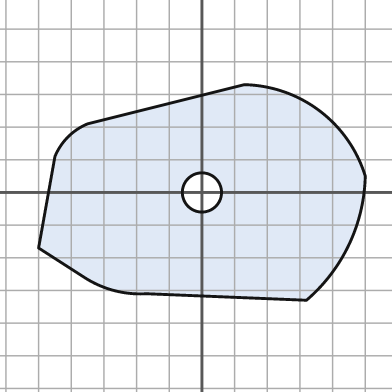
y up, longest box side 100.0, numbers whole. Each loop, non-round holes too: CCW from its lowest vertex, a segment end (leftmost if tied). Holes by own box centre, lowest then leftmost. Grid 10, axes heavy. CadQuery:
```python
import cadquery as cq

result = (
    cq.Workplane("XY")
    .moveTo(32.0, -33.0)
    .threePointArc((45.0, -16.0), (50.0, 5.0))
    .threePointArc((36.0, 25.0), (13.0, 33.0))
    .lineTo(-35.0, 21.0)
    .threePointArc((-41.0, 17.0), (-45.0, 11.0))
    .lineTo(-50.0, -17.0)
    .lineTo(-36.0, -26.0)
    .threePointArc((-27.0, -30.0), (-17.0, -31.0))
    .close()
    .moveTo(0.0, 0.0)
    .circle(6.0)
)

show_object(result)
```